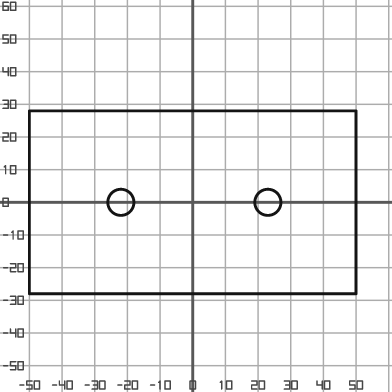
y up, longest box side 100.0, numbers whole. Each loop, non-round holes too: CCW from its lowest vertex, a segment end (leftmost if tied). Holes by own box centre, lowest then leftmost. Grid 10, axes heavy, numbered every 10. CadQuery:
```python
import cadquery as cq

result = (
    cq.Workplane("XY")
    .moveTo(-50.0, -28.0)
    .lineTo(50.0, -28.0)
    .lineTo(50.0, 28.0)
    .lineTo(-50.0, 28.0)
    .close()
    .moveTo(-22.0, 0.0)
    .circle(4.0)
    .moveTo(23.0, 0.0)
    .circle(4.0)
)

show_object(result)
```